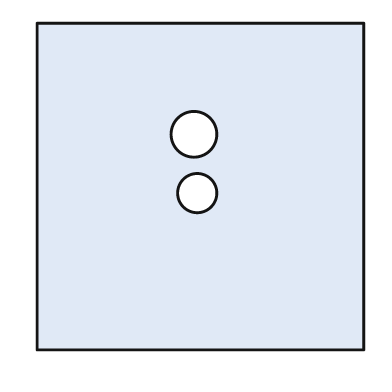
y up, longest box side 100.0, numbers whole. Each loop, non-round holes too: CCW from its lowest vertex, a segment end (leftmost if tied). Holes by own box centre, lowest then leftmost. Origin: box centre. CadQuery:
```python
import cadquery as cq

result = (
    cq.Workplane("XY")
    .moveTo(-50.0, -50.0)
    .lineTo(50.0, -50.0)
    .lineTo(50.0, 50.0)
    .lineTo(-50.0, 50.0)
    .close()
    .moveTo(-1.0, -2.0)
    .circle(6.0)
    .moveTo(-2.0, 16.0)
    .circle(7.0)
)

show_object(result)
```